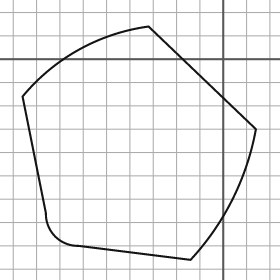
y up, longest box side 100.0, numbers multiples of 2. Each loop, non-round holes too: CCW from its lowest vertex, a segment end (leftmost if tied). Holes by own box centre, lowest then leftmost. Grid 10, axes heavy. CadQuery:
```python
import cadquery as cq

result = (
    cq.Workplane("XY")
    .moveTo(-14.0, -86.0)
    .threePointArc((4.0, -60.0), (14.0, -30.0))
    .lineTo(-32.0, 14.0)
    .threePointArc((-62.0, 4.0), (-86.0, -16.0))
    .lineTo(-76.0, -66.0)
    .threePointArc((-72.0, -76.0), (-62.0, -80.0))
    .close()
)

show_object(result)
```